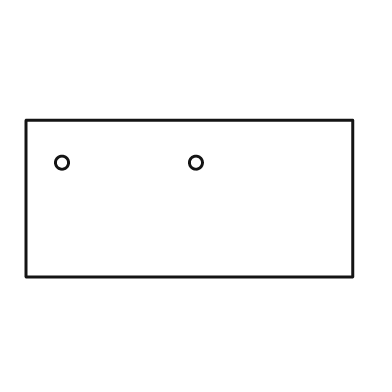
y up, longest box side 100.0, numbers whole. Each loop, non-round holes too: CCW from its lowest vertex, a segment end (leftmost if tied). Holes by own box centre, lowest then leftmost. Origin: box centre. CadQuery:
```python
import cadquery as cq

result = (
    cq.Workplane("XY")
    .moveTo(-50.0, -24.0)
    .lineTo(50.0, -24.0)
    .lineTo(50.0, 24.0)
    .lineTo(-50.0, 24.0)
    .close()
    .moveTo(-39.0, 11.0)
    .circle(2.0)
    .moveTo(2.0, 11.0)
    .circle(2.0)
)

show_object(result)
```